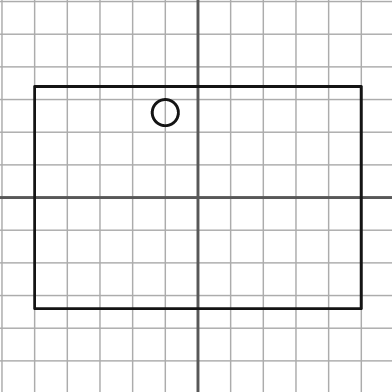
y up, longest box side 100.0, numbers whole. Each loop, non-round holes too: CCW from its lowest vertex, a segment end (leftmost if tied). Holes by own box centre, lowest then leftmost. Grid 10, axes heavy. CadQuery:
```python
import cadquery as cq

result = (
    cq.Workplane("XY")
    .moveTo(-50.0, -34.0)
    .lineTo(50.0, -34.0)
    .lineTo(50.0, 34.0)
    .lineTo(-50.0, 34.0)
    .close()
    .moveTo(-10.0, 26.0)
    .circle(4.0)
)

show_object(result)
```